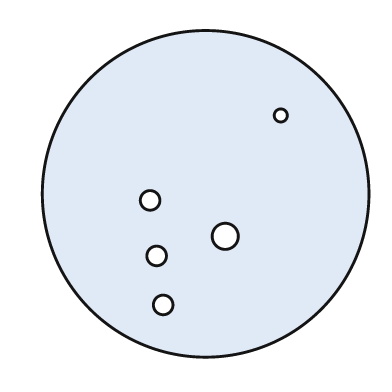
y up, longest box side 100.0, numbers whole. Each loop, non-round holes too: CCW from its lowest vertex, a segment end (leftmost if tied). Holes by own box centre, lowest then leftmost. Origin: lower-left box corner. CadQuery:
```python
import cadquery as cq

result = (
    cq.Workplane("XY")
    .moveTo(50.0, 50.0)
    .circle(50.0)
    .moveTo(37.0, 16.0)
    .circle(3.0)
    .moveTo(35.0, 31.0)
    .circle(3.0)
    .moveTo(56.0, 37.0)
    .circle(4.0)
    .moveTo(33.0, 48.0)
    .circle(3.0)
    .moveTo(73.0, 74.0)
    .circle(2.0)
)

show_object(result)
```